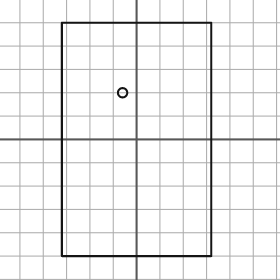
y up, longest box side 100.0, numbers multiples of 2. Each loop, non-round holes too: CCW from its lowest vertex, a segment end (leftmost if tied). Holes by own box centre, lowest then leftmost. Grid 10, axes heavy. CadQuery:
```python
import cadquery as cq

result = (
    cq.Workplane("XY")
    .moveTo(-32.0, -50.0)
    .lineTo(32.0, -50.0)
    .lineTo(32.0, 50.0)
    .lineTo(-32.0, 50.0)
    .close()
    .moveTo(-6.0, 20.0)
    .circle(2.0)
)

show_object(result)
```